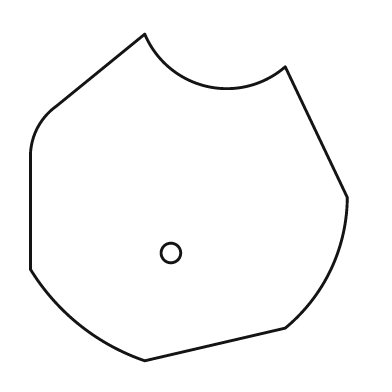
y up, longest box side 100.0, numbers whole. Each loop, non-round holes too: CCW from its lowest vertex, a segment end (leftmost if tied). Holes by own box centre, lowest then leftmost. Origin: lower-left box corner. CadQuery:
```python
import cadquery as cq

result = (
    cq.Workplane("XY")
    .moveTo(35.0, 0.0)
    .lineTo(78.0, 10.0)
    .threePointArc((92.0, 28.0), (97.0, 50.0))
    .lineTo(78.0, 90.0)
    .threePointArc((54.0, 84.0), (35.0, 100.0))
    .lineTo(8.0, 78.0)
    .threePointArc((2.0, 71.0), (0.0, 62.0))
    .lineTo(0.0, 28.0)
    .threePointArc((15.0, 11.0), (35.0, 0.0))
    .close()
    .moveTo(43.0, 33.0)
    .circle(3.0)
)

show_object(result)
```